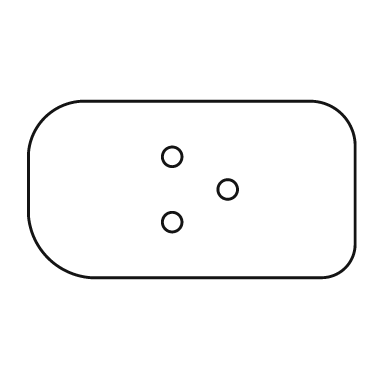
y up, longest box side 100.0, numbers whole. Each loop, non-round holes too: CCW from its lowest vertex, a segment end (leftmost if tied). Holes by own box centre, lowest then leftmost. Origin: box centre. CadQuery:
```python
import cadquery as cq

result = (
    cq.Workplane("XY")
    .moveTo(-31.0, -27.0)
    .lineTo(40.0, -27.0)
    .threePointArc((47.0, -24.0), (50.0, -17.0))
    .lineTo(50.0, 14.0)
    .threePointArc((46.0, 23.0), (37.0, 27.0))
    .lineTo(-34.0, 27.0)
    .threePointArc((-45.0, 22.0), (-50.0, 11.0))
    .lineTo(-50.0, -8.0)
    .threePointArc((-44.0, -21.0), (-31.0, -27.0))
    .close()
    .moveTo(-6.0, -10.0)
    .circle(3.0)
    .moveTo(11.0, 0.0)
    .circle(3.0)
    .moveTo(-6.0, 10.0)
    .circle(3.0)
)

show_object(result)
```